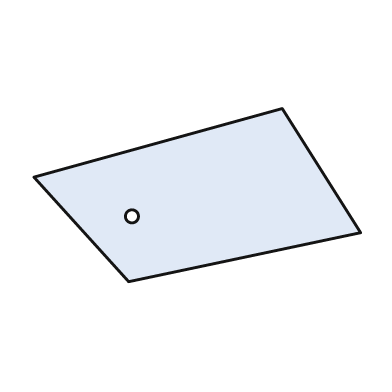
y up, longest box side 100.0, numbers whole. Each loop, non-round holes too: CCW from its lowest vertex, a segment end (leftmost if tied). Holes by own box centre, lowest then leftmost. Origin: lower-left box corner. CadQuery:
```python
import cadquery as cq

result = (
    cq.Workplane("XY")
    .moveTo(29.0, 0.0)
    .lineTo(100.0, 15.0)
    .lineTo(76.0, 53.0)
    .lineTo(0.0, 32.0)
    .close()
    .moveTo(30.0, 20.0)
    .circle(2.0)
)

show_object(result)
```